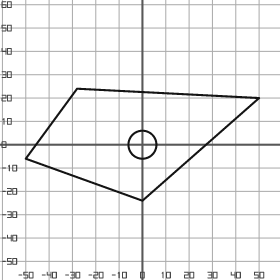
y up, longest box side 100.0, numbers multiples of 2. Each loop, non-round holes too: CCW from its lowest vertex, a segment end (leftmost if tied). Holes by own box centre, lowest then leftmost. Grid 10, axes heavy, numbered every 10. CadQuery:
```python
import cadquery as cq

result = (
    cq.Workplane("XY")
    .moveTo(0.0, -24.0)
    .lineTo(50.0, 20.0)
    .lineTo(-28.0, 24.0)
    .lineTo(-50.0, -6.0)
    .close()
    .moveTo(0.0, 0.0)
    .circle(6.0)
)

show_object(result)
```